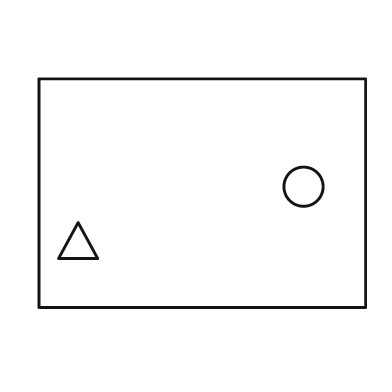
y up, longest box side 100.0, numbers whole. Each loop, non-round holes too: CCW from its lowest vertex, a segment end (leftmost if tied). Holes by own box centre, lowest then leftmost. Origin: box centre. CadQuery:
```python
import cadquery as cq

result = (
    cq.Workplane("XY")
    .moveTo(-50.0, -35.0)
    .lineTo(50.0, -35.0)
    .lineTo(50.0, 35.0)
    .lineTo(-50.0, 35.0)
    .close()
    .moveTo(-44.0, -20.0)
    .lineTo(-32.0, -20.0)
    .lineTo(-38.0, -9.0)
    .close()
    .moveTo(31.0, 2.0)
    .circle(6.0)
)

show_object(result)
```